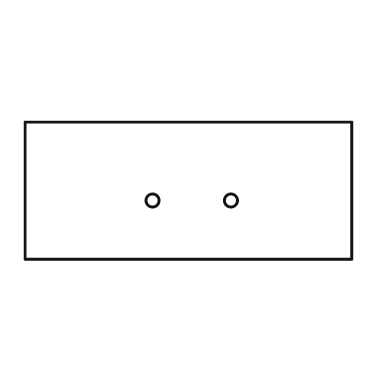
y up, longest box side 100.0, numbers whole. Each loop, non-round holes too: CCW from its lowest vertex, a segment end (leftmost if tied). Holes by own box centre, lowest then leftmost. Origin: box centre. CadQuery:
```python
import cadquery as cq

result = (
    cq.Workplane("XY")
    .moveTo(-50.0, -21.0)
    .lineTo(50.0, -21.0)
    .lineTo(50.0, 21.0)
    .lineTo(-50.0, 21.0)
    .close()
    .moveTo(-11.0, -3.0)
    .circle(2.0)
    .moveTo(13.0, -3.0)
    .circle(2.0)
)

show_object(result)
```